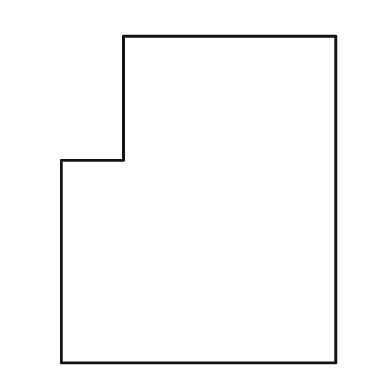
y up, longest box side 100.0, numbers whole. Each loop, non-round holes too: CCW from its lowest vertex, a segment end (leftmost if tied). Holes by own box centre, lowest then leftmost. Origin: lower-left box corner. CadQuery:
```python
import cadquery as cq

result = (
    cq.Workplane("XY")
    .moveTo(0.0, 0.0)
    .lineTo(84.0, 0.0)
    .lineTo(84.0, 100.0)
    .lineTo(19.0, 100.0)
    .lineTo(19.0, 62.0)
    .lineTo(0.0, 62.0)
    .close()
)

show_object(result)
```